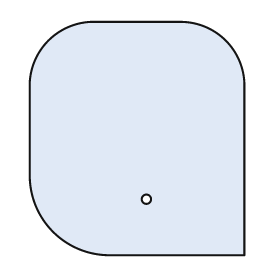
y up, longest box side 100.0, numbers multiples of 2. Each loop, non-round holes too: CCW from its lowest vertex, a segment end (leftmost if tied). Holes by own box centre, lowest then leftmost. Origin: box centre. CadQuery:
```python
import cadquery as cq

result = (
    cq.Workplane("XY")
    .moveTo(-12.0, -50.0)
    .lineTo(46.0, -50.0)
    .lineTo(46.0, 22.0)
    .threePointArc((38.0, 42.0), (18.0, 50.0))
    .lineTo(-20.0, 50.0)
    .threePointArc((-38.0, 42.0), (-46.0, 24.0))
    .lineTo(-46.0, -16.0)
    .threePointArc((-36.0, -40.0), (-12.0, -50.0))
    .close()
    .moveTo(4.0, -26.0)
    .circle(2.0)
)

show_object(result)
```